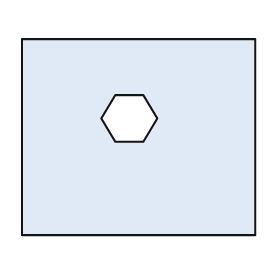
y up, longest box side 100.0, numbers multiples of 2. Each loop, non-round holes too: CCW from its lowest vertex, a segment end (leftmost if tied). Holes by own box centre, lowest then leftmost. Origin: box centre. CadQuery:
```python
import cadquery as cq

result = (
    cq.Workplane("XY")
    .moveTo(-50.0, -42.0)
    .lineTo(50.0, -42.0)
    .lineTo(50.0, 42.0)
    .lineTo(-50.0, 42.0)
    .close()
    .moveTo(-10.0, -2.0)
    .lineTo(2.0, -2.0)
    .lineTo(8.0, 8.0)
    .lineTo(2.0, 18.0)
    .lineTo(-10.0, 18.0)
    .lineTo(-16.0, 8.0)
    .close()
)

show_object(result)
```